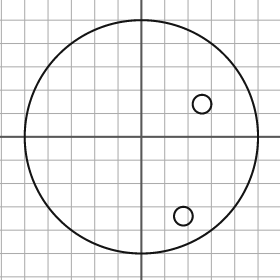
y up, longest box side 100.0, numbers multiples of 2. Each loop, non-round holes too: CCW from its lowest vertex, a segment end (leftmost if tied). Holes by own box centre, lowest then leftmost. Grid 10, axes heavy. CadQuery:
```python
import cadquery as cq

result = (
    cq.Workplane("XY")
    .moveTo(0.0, 0.0)
    .circle(50.0)
    .moveTo(18.0, -34.0)
    .circle(4.0)
    .moveTo(26.0, 14.0)
    .circle(4.0)
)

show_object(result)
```